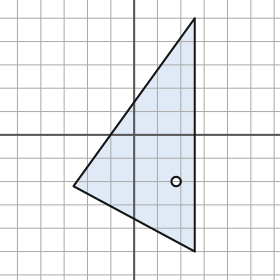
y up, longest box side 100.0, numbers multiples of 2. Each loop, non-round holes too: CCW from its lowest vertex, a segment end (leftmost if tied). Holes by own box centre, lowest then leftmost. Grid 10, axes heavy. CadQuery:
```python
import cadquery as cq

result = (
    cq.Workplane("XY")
    .moveTo(26.0, -50.0)
    .lineTo(26.0, 50.0)
    .lineTo(-26.0, -22.0)
    .close()
    .moveTo(18.0, -20.0)
    .circle(2.0)
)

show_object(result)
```